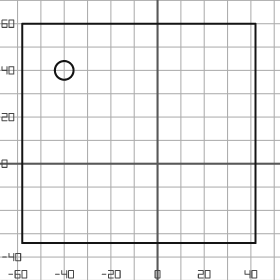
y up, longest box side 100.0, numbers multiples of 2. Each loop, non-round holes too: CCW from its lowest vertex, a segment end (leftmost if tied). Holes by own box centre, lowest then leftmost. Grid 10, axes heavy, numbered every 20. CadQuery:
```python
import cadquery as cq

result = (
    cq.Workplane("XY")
    .moveTo(-58.0, -34.0)
    .lineTo(42.0, -34.0)
    .lineTo(42.0, 60.0)
    .lineTo(-58.0, 60.0)
    .close()
    .moveTo(-40.0, 40.0)
    .circle(4.0)
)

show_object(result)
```